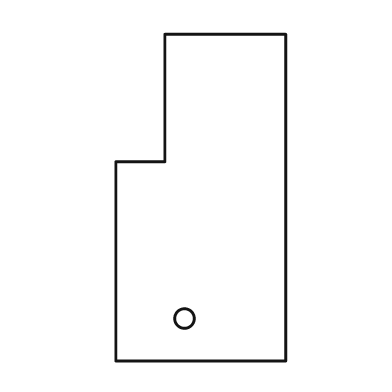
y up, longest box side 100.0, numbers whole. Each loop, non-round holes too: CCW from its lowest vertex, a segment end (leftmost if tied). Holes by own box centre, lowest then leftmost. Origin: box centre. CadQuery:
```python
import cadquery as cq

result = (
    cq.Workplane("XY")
    .moveTo(-26.0, -50.0)
    .lineTo(26.0, -50.0)
    .lineTo(26.0, 50.0)
    .lineTo(-11.0, 50.0)
    .lineTo(-11.0, 11.0)
    .lineTo(-26.0, 11.0)
    .close()
    .moveTo(-5.0, -37.0)
    .circle(3.0)
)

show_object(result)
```